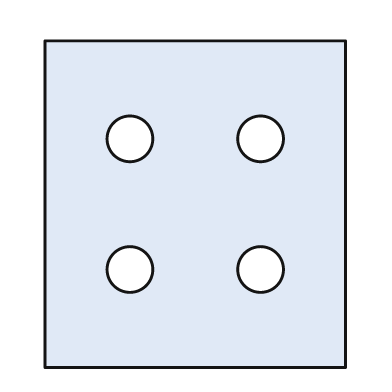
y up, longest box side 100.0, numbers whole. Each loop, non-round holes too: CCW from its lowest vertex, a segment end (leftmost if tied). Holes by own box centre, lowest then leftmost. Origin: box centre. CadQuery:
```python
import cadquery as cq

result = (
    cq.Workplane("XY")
    .moveTo(-46.0, -50.0)
    .lineTo(46.0, -50.0)
    .lineTo(46.0, 50.0)
    .lineTo(-46.0, 50.0)
    .close()
    .moveTo(-20.0, -20.0)
    .circle(7.0)
    .moveTo(20.0, -20.0)
    .circle(7.0)
    .moveTo(-20.0, 20.0)
    .circle(7.0)
    .moveTo(20.0, 20.0)
    .circle(7.0)
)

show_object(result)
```